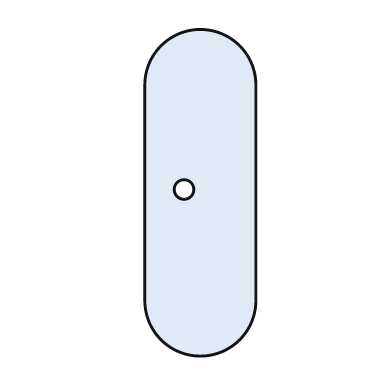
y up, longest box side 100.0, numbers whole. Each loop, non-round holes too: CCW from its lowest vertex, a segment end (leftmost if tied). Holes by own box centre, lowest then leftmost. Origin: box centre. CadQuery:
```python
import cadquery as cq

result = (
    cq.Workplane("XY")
    .moveTo(-17.0, -33.0)
    .threePointArc((0.0, -50.0), (17.0, -33.0))
    .lineTo(17.0, 33.0)
    .threePointArc((0.0, 50.0), (-17.0, 33.0))
    .close()
    .moveTo(-5.0, 1.0)
    .circle(3.0)
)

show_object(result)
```